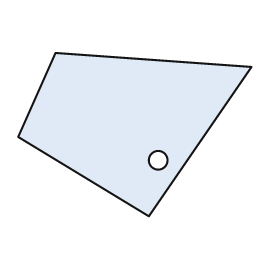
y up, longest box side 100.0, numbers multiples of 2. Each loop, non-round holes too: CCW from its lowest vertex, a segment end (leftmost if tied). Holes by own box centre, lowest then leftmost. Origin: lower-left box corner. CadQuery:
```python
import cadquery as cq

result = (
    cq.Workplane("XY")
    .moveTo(56.0, 0.0)
    .lineTo(100.0, 64.0)
    .lineTo(16.0, 70.0)
    .lineTo(0.0, 34.0)
    .close()
    .moveTo(60.0, 24.0)
    .circle(4.0)
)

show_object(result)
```